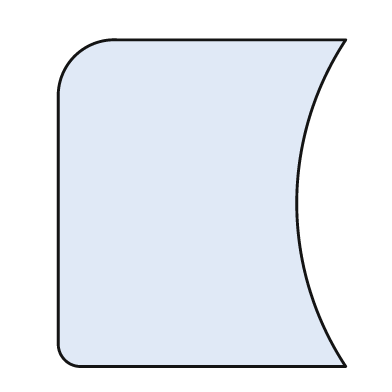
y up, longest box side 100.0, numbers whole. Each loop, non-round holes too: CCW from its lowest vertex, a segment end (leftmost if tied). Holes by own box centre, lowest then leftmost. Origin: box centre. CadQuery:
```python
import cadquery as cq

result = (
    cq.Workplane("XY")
    .moveTo(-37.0, -50.0)
    .lineTo(44.0, -50.0)
    .threePointArc((29.0, 0.0), (44.0, 50.0))
    .lineTo(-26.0, 50.0)
    .threePointArc((-39.0, 45.0), (-44.0, 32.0))
    .lineTo(-44.0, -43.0)
    .threePointArc((-42.0, -48.0), (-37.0, -50.0))
    .close()
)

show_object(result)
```